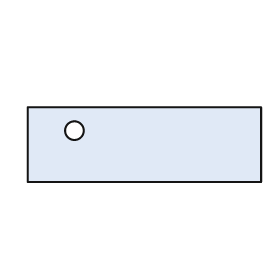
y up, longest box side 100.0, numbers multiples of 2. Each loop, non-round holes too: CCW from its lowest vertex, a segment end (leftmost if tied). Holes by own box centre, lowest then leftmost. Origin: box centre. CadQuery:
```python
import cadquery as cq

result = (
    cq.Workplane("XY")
    .moveTo(-50.0, -16.0)
    .lineTo(50.0, -16.0)
    .lineTo(50.0, 16.0)
    .lineTo(-50.0, 16.0)
    .close()
    .moveTo(-30.0, 6.0)
    .circle(4.0)
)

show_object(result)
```